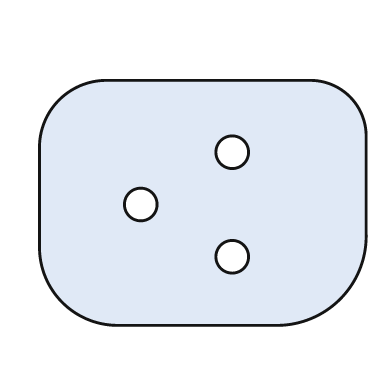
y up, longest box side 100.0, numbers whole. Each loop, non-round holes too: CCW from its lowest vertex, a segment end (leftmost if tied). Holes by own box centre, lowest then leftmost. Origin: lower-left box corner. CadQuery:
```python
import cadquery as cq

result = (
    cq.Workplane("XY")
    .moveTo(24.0, 0.0)
    .lineTo(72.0, 0.0)
    .threePointArc((92.0, 8.0), (100.0, 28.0))
    .lineTo(100.0, 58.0)
    .threePointArc((95.0, 70.0), (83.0, 75.0))
    .lineTo(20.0, 75.0)
    .threePointArc((6.0, 69.0), (0.0, 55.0))
    .lineTo(0.0, 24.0)
    .threePointArc((7.0, 7.0), (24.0, 0.0))
    .close()
    .moveTo(59.0, 21.0)
    .circle(5.0)
    .moveTo(31.0, 37.0)
    .circle(5.0)
    .moveTo(59.0, 53.0)
    .circle(5.0)
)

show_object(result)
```